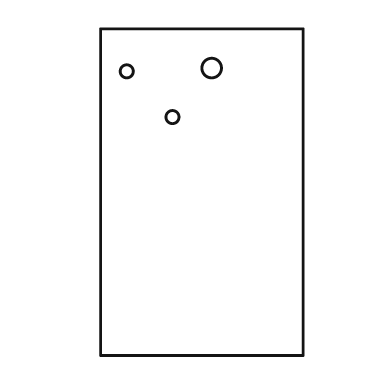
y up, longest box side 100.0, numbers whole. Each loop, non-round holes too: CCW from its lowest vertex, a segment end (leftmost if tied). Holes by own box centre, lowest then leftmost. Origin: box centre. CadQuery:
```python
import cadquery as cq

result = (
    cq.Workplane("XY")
    .moveTo(-31.0, -50.0)
    .lineTo(31.0, -50.0)
    .lineTo(31.0, 50.0)
    .lineTo(-31.0, 50.0)
    .close()
    .moveTo(-9.0, 23.0)
    .circle(2.0)
    .moveTo(-23.0, 37.0)
    .circle(2.0)
    .moveTo(3.0, 38.0)
    .circle(3.0)
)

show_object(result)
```